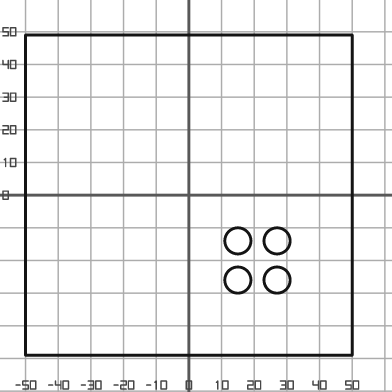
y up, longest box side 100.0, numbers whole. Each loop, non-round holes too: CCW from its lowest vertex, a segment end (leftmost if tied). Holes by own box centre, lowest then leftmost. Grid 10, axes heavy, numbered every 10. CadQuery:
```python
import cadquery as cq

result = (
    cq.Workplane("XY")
    .moveTo(-50.0, -49.0)
    .lineTo(50.0, -49.0)
    .lineTo(50.0, 49.0)
    .lineTo(-50.0, 49.0)
    .close()
    .moveTo(15.0, -26.0)
    .circle(4.0)
    .moveTo(27.0, -26.0)
    .circle(4.0)
    .moveTo(15.0, -14.0)
    .circle(4.0)
    .moveTo(27.0, -14.0)
    .circle(4.0)
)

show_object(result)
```